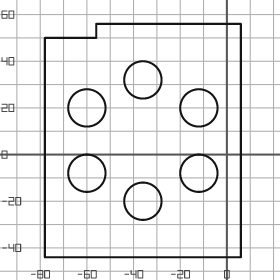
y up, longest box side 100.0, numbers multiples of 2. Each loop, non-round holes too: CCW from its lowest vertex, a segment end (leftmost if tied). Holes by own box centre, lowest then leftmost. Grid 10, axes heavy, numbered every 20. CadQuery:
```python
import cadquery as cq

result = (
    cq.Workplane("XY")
    .moveTo(-78.0, -44.0)
    .lineTo(6.0, -44.0)
    .lineTo(6.0, 56.0)
    .lineTo(-56.0, 56.0)
    .lineTo(-56.0, 50.0)
    .lineTo(-78.0, 50.0)
    .close()
    .moveTo(-36.0, -20.0)
    .circle(8.0)
    .moveTo(-60.0, -8.0)
    .circle(8.0)
    .moveTo(-12.0, -8.0)
    .circle(8.0)
    .moveTo(-60.0, 20.0)
    .circle(8.0)
    .moveTo(-12.0, 20.0)
    .circle(8.0)
    .moveTo(-36.0, 32.0)
    .circle(8.0)
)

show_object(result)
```